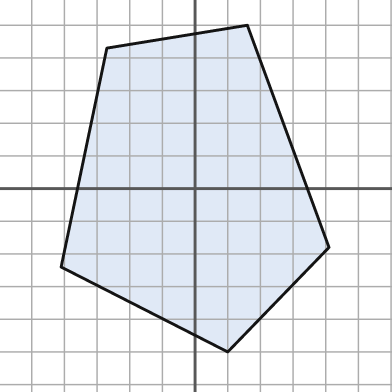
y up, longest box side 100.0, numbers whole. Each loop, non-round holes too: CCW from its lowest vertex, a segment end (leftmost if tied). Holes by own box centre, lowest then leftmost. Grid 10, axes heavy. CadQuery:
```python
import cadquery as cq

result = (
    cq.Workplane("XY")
    .moveTo(10.0, -50.0)
    .lineTo(41.0, -18.0)
    .lineTo(16.0, 50.0)
    .lineTo(-27.0, 43.0)
    .lineTo(-41.0, -24.0)
    .close()
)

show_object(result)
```